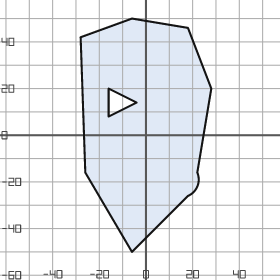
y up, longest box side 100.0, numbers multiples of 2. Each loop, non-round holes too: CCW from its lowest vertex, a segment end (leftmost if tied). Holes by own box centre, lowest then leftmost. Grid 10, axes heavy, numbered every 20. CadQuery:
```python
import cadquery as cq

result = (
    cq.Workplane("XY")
    .moveTo(-6.0, -50.0)
    .lineTo(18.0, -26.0)
    .threePointArc((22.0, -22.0), (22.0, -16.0))
    .lineTo(28.0, 20.0)
    .lineTo(18.0, 46.0)
    .lineTo(-6.0, 50.0)
    .lineTo(-28.0, 42.0)
    .lineTo(-26.0, -16.0)
    .close()
    .moveTo(-16.0, 8.0)
    .lineTo(-4.0, 14.0)
    .lineTo(-16.0, 20.0)
    .close()
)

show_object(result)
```